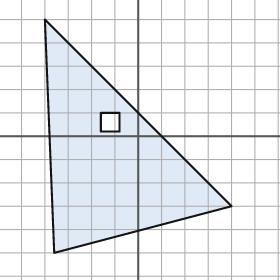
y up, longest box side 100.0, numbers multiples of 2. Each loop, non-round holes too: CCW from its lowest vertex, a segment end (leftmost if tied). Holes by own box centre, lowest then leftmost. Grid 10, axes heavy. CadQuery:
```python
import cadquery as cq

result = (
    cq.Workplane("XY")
    .moveTo(-36.0, -50.0)
    .lineTo(40.0, -30.0)
    .lineTo(-40.0, 50.0)
    .close()
    .moveTo(-16.0, 2.0)
    .lineTo(-8.0, 2.0)
    .lineTo(-8.0, 10.0)
    .lineTo(-16.0, 10.0)
    .close()
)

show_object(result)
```